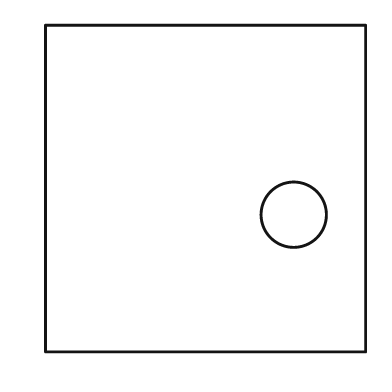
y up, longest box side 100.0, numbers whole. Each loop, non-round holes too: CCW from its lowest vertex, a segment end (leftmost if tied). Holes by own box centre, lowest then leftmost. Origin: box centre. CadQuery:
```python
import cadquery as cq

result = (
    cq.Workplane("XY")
    .moveTo(-49.0, -50.0)
    .lineTo(49.0, -50.0)
    .lineTo(49.0, 50.0)
    .lineTo(-49.0, 50.0)
    .close()
    .moveTo(27.0, -8.0)
    .circle(10.0)
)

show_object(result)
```